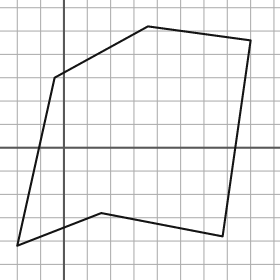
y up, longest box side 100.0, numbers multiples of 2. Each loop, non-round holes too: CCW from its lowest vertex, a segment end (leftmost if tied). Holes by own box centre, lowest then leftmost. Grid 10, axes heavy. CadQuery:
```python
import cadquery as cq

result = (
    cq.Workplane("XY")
    .moveTo(-20.0, -42.0)
    .lineTo(16.0, -28.0)
    .lineTo(68.0, -38.0)
    .lineTo(80.0, 46.0)
    .lineTo(36.0, 52.0)
    .lineTo(-4.0, 30.0)
    .close()
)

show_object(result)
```